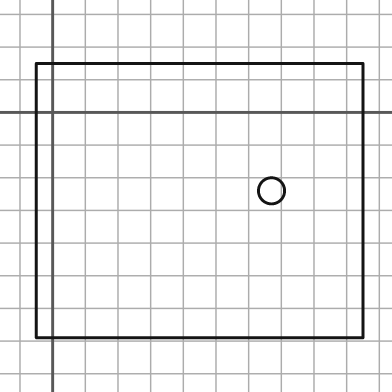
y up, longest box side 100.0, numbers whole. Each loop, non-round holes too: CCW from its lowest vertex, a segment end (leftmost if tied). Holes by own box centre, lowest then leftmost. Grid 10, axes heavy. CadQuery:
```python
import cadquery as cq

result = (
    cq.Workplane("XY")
    .moveTo(-5.0, -69.0)
    .lineTo(95.0, -69.0)
    .lineTo(95.0, 15.0)
    .lineTo(-5.0, 15.0)
    .close()
    .moveTo(67.0, -24.0)
    .circle(4.0)
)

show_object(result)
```